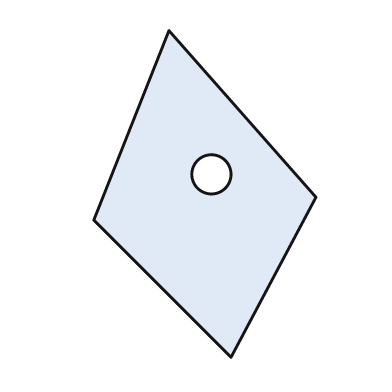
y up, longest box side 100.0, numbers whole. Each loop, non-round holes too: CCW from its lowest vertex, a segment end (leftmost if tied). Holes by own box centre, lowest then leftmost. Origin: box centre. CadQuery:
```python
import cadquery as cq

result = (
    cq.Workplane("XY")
    .moveTo(8.0, -50.0)
    .lineTo(34.0, -1.0)
    .lineTo(-11.0, 50.0)
    .lineTo(-34.0, -8.0)
    .close()
    .moveTo(2.0, 6.0)
    .circle(6.0)
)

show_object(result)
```